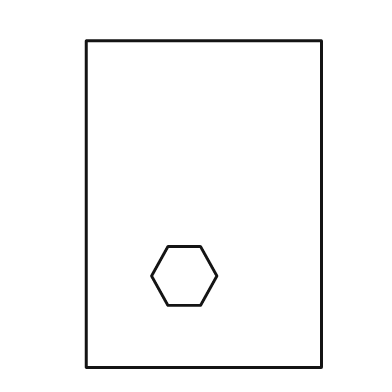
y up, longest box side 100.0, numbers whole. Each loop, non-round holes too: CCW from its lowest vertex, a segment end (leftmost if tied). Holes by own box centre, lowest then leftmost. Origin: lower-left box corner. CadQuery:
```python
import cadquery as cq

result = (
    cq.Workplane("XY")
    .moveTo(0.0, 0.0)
    .lineTo(72.0, 0.0)
    .lineTo(72.0, 100.0)
    .lineTo(0.0, 100.0)
    .close()
    .moveTo(25.0, 19.0)
    .lineTo(35.0, 19.0)
    .lineTo(40.0, 28.0)
    .lineTo(35.0, 37.0)
    .lineTo(25.0, 37.0)
    .lineTo(20.0, 28.0)
    .close()
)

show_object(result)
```